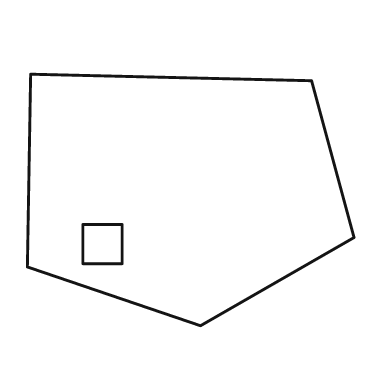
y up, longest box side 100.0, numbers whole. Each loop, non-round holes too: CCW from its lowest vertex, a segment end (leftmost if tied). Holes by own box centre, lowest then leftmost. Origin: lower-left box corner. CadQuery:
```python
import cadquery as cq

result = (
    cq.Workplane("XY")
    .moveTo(53.0, 0.0)
    .lineTo(100.0, 27.0)
    .lineTo(87.0, 75.0)
    .lineTo(1.0, 77.0)
    .lineTo(0.0, 18.0)
    .close()
    .moveTo(17.0, 19.0)
    .lineTo(29.0, 19.0)
    .lineTo(29.0, 31.0)
    .lineTo(17.0, 31.0)
    .close()
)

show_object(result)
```